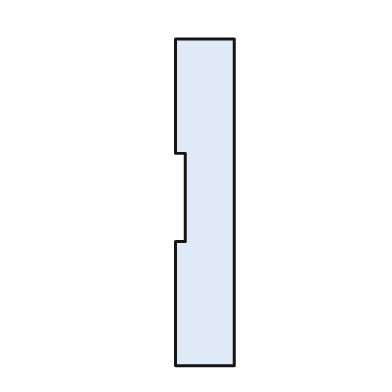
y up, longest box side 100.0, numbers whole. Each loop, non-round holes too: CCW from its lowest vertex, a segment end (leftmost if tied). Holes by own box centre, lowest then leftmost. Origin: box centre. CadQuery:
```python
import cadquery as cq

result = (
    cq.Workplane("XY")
    .moveTo(-9.0, -50.0)
    .lineTo(9.0, -50.0)
    .lineTo(9.0, 50.0)
    .lineTo(-9.0, 50.0)
    .lineTo(-9.0, 15.0)
    .lineTo(-6.0, 15.0)
    .lineTo(-6.0, -12.0)
    .lineTo(-9.0, -12.0)
    .close()
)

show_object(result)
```